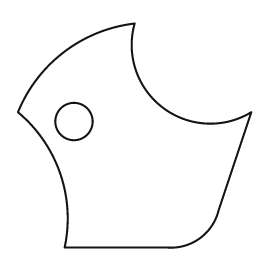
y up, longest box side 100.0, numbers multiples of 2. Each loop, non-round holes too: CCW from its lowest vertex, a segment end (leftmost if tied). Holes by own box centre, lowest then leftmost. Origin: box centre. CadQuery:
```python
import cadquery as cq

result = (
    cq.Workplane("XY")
    .moveTo(-30.0, -48.0)
    .lineTo(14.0, -48.0)
    .threePointArc((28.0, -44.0), (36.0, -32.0))
    .lineTo(50.0, 10.0)
    .threePointArc((12.0, 12.0), (0.0, 48.0))
    .threePointArc((-30.0, 36.0), (-50.0, 10.0))
    .threePointArc((-32.0, -16.0), (-30.0, -48.0))
    .close()
    .moveTo(-26.0, 6.0)
    .circle(8.0)
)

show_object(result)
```